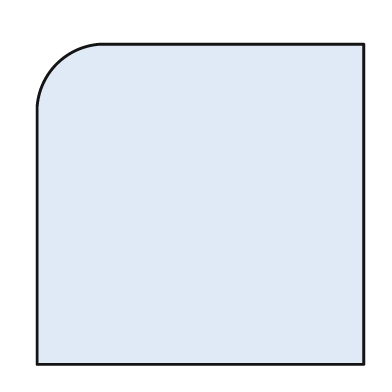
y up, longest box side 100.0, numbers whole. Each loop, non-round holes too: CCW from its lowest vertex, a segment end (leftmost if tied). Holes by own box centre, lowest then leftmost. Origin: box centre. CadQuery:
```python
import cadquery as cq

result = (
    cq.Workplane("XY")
    .moveTo(-50.0, -49.0)
    .lineTo(50.0, -49.0)
    .lineTo(50.0, 49.0)
    .lineTo(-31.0, 49.0)
    .threePointArc((-44.0, 43.0), (-50.0, 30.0))
    .close()
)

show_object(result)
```